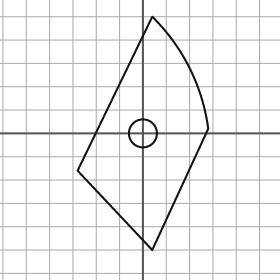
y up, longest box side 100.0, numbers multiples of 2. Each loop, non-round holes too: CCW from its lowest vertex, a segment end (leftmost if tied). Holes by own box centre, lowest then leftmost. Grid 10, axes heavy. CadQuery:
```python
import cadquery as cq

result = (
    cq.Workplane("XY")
    .moveTo(4.0, -50.0)
    .lineTo(28.0, 2.0)
    .threePointArc((20.0, 28.0), (4.0, 50.0))
    .lineTo(-28.0, -16.0)
    .close()
    .moveTo(0.0, 0.0)
    .circle(6.0)
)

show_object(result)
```